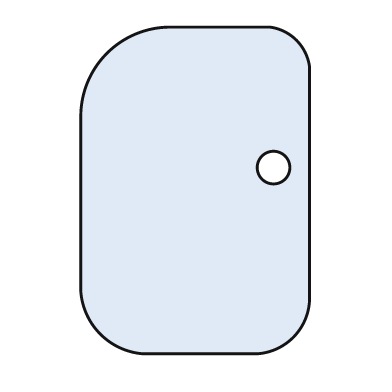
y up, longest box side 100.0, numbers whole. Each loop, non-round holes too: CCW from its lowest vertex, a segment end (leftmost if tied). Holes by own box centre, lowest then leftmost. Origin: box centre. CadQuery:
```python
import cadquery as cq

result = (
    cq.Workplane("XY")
    .moveTo(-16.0, -50.0)
    .lineTo(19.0, -50.0)
    .threePointArc((30.0, -45.0), (35.0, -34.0))
    .lineTo(35.0, 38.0)
    .threePointArc((31.0, 46.0), (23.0, 50.0))
    .lineTo(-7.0, 50.0)
    .threePointArc((-27.0, 42.0), (-35.0, 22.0))
    .lineTo(-35.0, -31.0)
    .threePointArc((-29.0, -44.0), (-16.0, -50.0))
    .close()
    .moveTo(24.0, 7.0)
    .circle(5.0)
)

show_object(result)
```